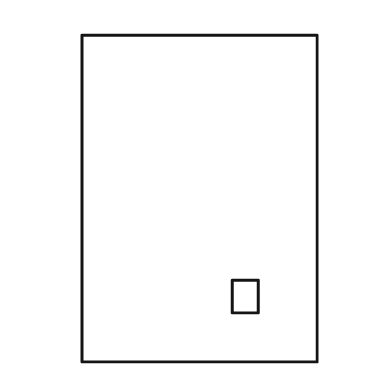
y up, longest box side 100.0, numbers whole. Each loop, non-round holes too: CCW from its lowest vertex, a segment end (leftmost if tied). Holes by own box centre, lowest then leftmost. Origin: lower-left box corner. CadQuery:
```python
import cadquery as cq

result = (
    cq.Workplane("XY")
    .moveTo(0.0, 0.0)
    .lineTo(72.0, 0.0)
    .lineTo(72.0, 100.0)
    .lineTo(0.0, 100.0)
    .close()
    .moveTo(46.0, 15.0)
    .lineTo(54.0, 15.0)
    .lineTo(54.0, 25.0)
    .lineTo(46.0, 25.0)
    .close()
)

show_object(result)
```